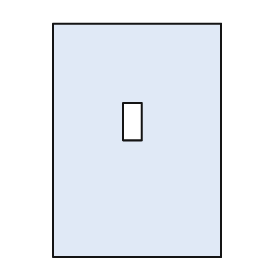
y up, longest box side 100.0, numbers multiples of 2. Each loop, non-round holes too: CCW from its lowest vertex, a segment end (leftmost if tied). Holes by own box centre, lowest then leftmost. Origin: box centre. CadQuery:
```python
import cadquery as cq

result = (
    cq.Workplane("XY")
    .moveTo(-36.0, -50.0)
    .lineTo(36.0, -50.0)
    .lineTo(36.0, 50.0)
    .lineTo(-36.0, 50.0)
    .close()
    .moveTo(-6.0, 0.0)
    .lineTo(2.0, 0.0)
    .lineTo(2.0, 16.0)
    .lineTo(-6.0, 16.0)
    .close()
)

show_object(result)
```